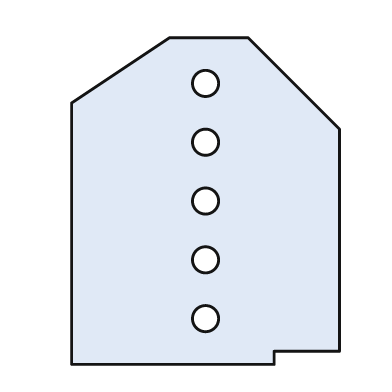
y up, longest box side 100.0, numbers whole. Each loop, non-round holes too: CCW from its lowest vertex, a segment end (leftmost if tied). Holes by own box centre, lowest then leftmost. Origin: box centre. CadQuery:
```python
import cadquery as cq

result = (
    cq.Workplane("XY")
    .moveTo(-41.0, -50.0)
    .lineTo(21.0, -50.0)
    .lineTo(21.0, -46.0)
    .lineTo(41.0, -46.0)
    .lineTo(41.0, 22.0)
    .lineTo(13.0, 50.0)
    .lineTo(-11.0, 50.0)
    .lineTo(-41.0, 30.0)
    .close()
    .moveTo(0.0, -36.0)
    .circle(4.0)
    .moveTo(0.0, -18.0)
    .circle(4.0)
    .moveTo(0.0, 0.0)
    .circle(4.0)
    .moveTo(0.0, 18.0)
    .circle(4.0)
    .moveTo(0.0, 36.0)
    .circle(4.0)
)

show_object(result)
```